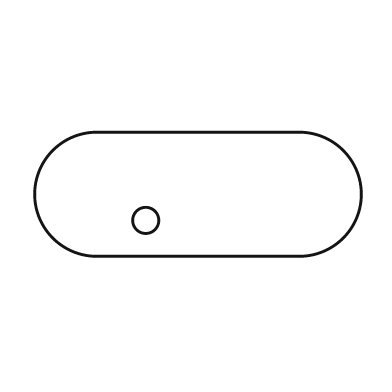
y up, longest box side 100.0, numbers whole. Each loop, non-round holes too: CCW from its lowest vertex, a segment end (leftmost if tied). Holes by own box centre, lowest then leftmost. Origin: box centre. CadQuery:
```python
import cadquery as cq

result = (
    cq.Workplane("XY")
    .moveTo(-31.0, -19.0)
    .lineTo(31.0, -19.0)
    .threePointArc((50.0, 0.0), (31.0, 19.0))
    .lineTo(-31.0, 19.0)
    .threePointArc((-50.0, 0.0), (-31.0, -19.0))
    .close()
    .moveTo(-16.0, -8.0)
    .circle(4.0)
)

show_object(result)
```